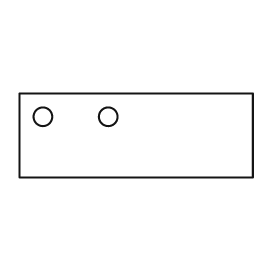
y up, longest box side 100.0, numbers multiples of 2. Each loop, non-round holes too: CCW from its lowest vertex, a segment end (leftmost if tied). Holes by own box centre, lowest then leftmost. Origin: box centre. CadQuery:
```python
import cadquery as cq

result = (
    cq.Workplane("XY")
    .moveTo(-50.0, -18.0)
    .lineTo(50.0, -18.0)
    .lineTo(50.0, 18.0)
    .lineTo(-50.0, 18.0)
    .close()
    .moveTo(-40.0, 8.0)
    .circle(4.0)
    .moveTo(-12.0, 8.0)
    .circle(4.0)
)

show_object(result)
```